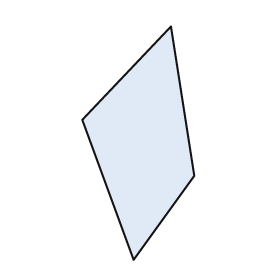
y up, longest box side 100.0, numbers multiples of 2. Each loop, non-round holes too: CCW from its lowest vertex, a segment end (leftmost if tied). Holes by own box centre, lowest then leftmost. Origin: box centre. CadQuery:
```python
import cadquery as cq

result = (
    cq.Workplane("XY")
    .moveTo(-2.0, -50.0)
    .lineTo(24.0, -14.0)
    .lineTo(14.0, 50.0)
    .lineTo(-24.0, 10.0)
    .close()
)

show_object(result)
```